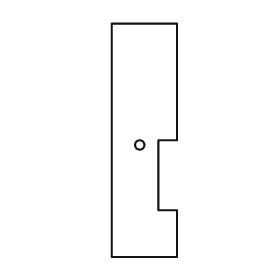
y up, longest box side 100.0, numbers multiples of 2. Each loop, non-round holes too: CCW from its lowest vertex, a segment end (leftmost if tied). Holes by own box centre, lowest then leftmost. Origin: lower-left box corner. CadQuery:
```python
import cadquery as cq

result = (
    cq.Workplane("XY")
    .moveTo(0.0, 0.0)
    .lineTo(28.0, 0.0)
    .lineTo(28.0, 20.0)
    .lineTo(20.0, 20.0)
    .lineTo(20.0, 50.0)
    .lineTo(28.0, 50.0)
    .lineTo(28.0, 100.0)
    .lineTo(0.0, 100.0)
    .close()
    .moveTo(12.0, 48.0)
    .circle(2.0)
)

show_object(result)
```